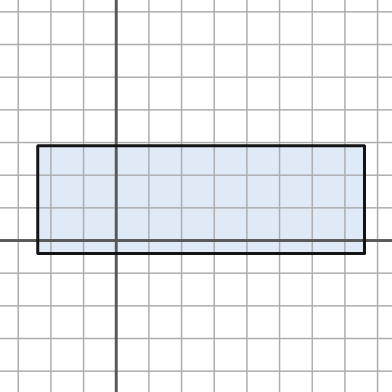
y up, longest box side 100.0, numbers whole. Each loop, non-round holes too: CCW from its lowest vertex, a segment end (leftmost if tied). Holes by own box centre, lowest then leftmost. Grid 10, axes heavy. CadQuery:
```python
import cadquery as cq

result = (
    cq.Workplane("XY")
    .moveTo(-24.0, -4.0)
    .lineTo(76.0, -4.0)
    .lineTo(76.0, 29.0)
    .lineTo(-24.0, 29.0)
    .close()
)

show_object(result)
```